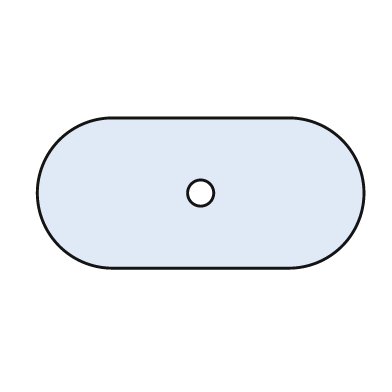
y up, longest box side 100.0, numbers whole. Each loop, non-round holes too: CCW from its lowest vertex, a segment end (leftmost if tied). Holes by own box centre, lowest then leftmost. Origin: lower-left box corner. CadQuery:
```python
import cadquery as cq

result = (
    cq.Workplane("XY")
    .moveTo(23.0, 0.0)
    .lineTo(77.0, 0.0)
    .threePointArc((100.0, 23.0), (77.0, 46.0))
    .lineTo(23.0, 46.0)
    .threePointArc((0.0, 23.0), (23.0, 0.0))
    .close()
    .moveTo(50.0, 23.0)
    .circle(4.0)
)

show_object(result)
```